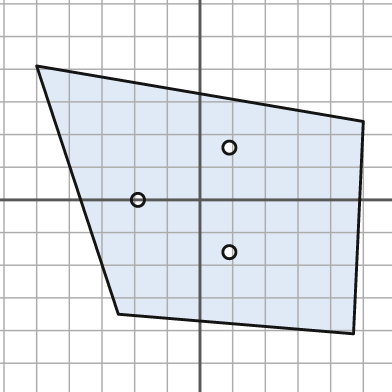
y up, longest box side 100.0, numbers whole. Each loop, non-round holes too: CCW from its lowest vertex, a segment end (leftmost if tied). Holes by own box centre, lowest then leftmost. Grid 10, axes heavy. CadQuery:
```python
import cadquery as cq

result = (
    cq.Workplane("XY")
    .moveTo(47.0, -41.0)
    .lineTo(50.0, 24.0)
    .lineTo(-50.0, 41.0)
    .lineTo(-25.0, -35.0)
    .close()
    .moveTo(9.0, -16.0)
    .circle(2.0)
    .moveTo(-19.0, 0.0)
    .circle(2.0)
    .moveTo(9.0, 16.0)
    .circle(2.0)
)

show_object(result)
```